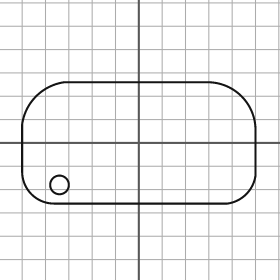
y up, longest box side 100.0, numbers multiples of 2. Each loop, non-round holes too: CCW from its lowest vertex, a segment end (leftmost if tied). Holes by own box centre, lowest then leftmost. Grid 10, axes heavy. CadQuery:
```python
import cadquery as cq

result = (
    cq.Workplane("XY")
    .moveTo(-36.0, -26.0)
    .lineTo(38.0, -26.0)
    .threePointArc((46.0, -22.0), (50.0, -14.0))
    .lineTo(50.0, 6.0)
    .threePointArc((44.0, 20.0), (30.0, 26.0))
    .lineTo(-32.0, 26.0)
    .threePointArc((-44.0, 20.0), (-50.0, 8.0))
    .lineTo(-50.0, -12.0)
    .threePointArc((-46.0, -22.0), (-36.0, -26.0))
    .close()
    .moveTo(-34.0, -18.0)
    .circle(4.0)
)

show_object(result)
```